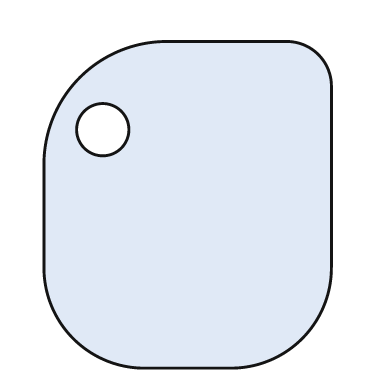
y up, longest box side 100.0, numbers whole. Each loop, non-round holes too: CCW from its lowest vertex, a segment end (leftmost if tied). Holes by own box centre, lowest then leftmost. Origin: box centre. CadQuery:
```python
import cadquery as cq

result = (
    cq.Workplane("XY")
    .moveTo(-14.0, -50.0)
    .lineTo(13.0, -50.0)
    .threePointArc((35.0, -41.0), (44.0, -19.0))
    .lineTo(44.0, 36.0)
    .threePointArc((40.0, 46.0), (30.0, 50.0))
    .lineTo(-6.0, 50.0)
    .threePointArc((-33.0, 39.0), (-44.0, 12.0))
    .lineTo(-44.0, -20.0)
    .threePointArc((-35.0, -41.0), (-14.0, -50.0))
    .close()
    .moveTo(-26.0, 23.0)
    .circle(8.0)
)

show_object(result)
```